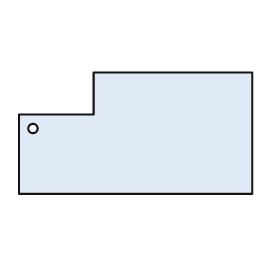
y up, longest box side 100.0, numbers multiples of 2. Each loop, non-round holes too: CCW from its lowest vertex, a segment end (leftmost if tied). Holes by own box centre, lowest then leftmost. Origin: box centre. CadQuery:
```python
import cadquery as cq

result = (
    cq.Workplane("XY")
    .moveTo(-50.0, -26.0)
    .lineTo(50.0, -26.0)
    .lineTo(50.0, 26.0)
    .lineTo(-18.0, 26.0)
    .lineTo(-18.0, 8.0)
    .lineTo(-50.0, 8.0)
    .close()
    .moveTo(-44.0, 2.0)
    .circle(2.0)
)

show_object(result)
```